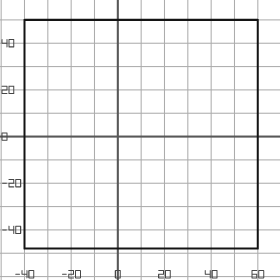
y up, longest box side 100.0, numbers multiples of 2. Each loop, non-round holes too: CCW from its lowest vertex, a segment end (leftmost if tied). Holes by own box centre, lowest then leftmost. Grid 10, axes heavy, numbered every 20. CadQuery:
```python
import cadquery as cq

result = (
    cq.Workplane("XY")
    .moveTo(-40.0, -48.0)
    .lineTo(60.0, -48.0)
    .lineTo(60.0, 50.0)
    .lineTo(-40.0, 50.0)
    .close()
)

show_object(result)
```